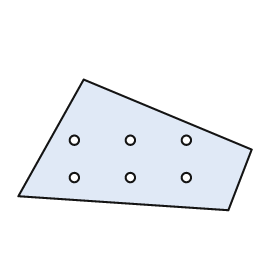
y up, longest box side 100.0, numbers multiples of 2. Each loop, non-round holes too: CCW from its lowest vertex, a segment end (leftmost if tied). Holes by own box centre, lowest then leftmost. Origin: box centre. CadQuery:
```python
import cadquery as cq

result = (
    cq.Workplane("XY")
    .moveTo(40.0, -28.0)
    .lineTo(50.0, -2.0)
    .lineTo(-22.0, 28.0)
    .lineTo(-50.0, -22.0)
    .close()
    .moveTo(-26.0, -14.0)
    .circle(2.0)
    .moveTo(-2.0, -14.0)
    .circle(2.0)
    .moveTo(22.0, -14.0)
    .circle(2.0)
    .moveTo(-26.0, 2.0)
    .circle(2.0)
    .moveTo(-2.0, 2.0)
    .circle(2.0)
    .moveTo(22.0, 2.0)
    .circle(2.0)
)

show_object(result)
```